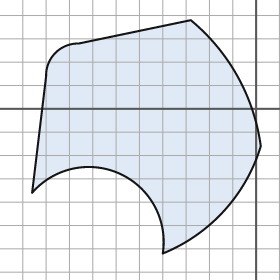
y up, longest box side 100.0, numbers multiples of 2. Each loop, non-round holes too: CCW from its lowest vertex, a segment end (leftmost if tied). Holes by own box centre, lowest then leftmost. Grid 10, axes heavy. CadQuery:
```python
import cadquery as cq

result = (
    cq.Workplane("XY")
    .moveTo(-40.0, -62.0)
    .threePointArc((-14.0, -44.0), (2.0, -16.0))
    .threePointArc((-8.0, 14.0), (-28.0, 38.0))
    .lineTo(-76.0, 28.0)
    .threePointArc((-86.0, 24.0), (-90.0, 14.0))
    .lineTo(-96.0, -36.0)
    .threePointArc((-58.0, -28.0), (-40.0, -62.0))
    .close()
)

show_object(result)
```